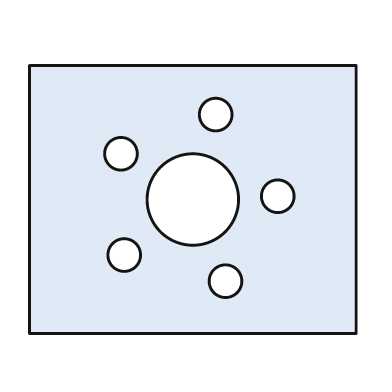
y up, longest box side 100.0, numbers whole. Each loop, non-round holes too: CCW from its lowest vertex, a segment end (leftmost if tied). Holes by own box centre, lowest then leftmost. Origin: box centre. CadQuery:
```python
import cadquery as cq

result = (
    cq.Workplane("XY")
    .moveTo(-50.0, -41.0)
    .lineTo(50.0, -41.0)
    .lineTo(50.0, 41.0)
    .lineTo(-50.0, 41.0)
    .close()
    .moveTo(10.0, -25.0)
    .circle(5.0)
    .moveTo(-21.0, -17.0)
    .circle(5.0)
    .moveTo(0.0, 0.0)
    .circle(14.0)
    .moveTo(26.0, 1.0)
    .circle(5.0)
    .moveTo(-22.0, 14.0)
    .circle(5.0)
    .moveTo(7.0, 26.0)
    .circle(5.0)
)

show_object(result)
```